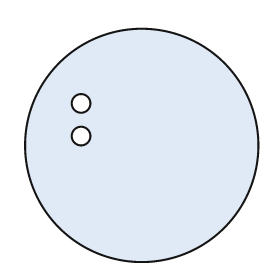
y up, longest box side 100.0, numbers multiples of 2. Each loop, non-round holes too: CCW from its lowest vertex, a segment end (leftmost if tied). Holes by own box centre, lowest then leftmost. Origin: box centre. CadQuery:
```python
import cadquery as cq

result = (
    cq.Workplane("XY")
    .moveTo(0.0, 0.0)
    .circle(50.0)
    .moveTo(-26.0, 4.0)
    .circle(4.0)
    .moveTo(-26.0, 18.0)
    .circle(4.0)
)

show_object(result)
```